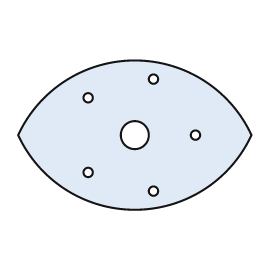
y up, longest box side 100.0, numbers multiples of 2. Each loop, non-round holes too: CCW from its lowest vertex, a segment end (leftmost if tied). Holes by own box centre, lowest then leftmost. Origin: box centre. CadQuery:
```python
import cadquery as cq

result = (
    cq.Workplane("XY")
    .moveTo(-50.0, 0.0)
    .threePointArc((0.0, -32.0), (50.0, 0.0))
    .threePointArc((0.0, 32.0), (-50.0, 0.0))
    .close()
    .moveTo(8.0, -24.0)
    .circle(2.0)
    .moveTo(-20.0, -16.0)
    .circle(2.0)
    .moveTo(0.0, 0.0)
    .circle(6.0)
    .moveTo(26.0, 0.0)
    .circle(2.0)
    .moveTo(-20.0, 16.0)
    .circle(2.0)
    .moveTo(8.0, 24.0)
    .circle(2.0)
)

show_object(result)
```